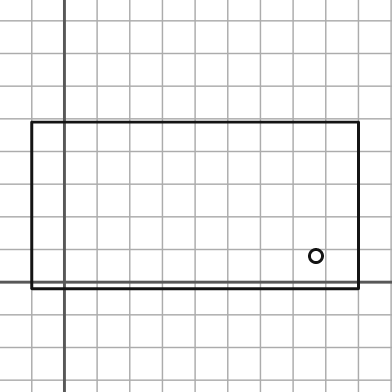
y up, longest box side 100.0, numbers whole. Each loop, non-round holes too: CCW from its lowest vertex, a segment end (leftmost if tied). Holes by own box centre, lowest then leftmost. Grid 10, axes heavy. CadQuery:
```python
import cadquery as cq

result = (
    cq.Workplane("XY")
    .moveTo(-10.0, -2.0)
    .lineTo(90.0, -2.0)
    .lineTo(90.0, 49.0)
    .lineTo(-10.0, 49.0)
    .close()
    .moveTo(77.0, 8.0)
    .circle(2.0)
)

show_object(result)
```